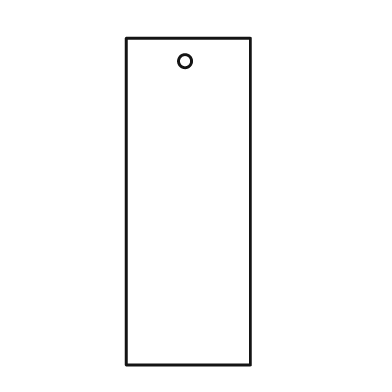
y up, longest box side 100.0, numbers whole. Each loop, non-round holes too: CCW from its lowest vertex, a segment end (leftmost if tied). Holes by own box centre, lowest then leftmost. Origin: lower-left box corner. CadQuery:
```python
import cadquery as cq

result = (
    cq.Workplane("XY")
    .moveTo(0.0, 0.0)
    .lineTo(38.0, 0.0)
    .lineTo(38.0, 100.0)
    .lineTo(0.0, 100.0)
    .close()
    .moveTo(18.0, 93.0)
    .circle(2.0)
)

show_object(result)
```